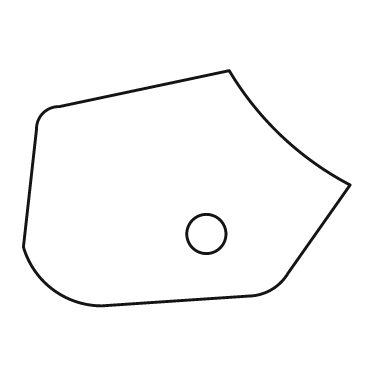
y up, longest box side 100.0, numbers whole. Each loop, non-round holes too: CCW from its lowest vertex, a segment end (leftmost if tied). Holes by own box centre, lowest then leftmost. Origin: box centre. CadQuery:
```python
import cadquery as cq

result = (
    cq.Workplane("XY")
    .moveTo(-26.0, -36.0)
    .lineTo(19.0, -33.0)
    .threePointArc((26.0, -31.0), (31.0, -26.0))
    .lineTo(50.0, 1.0)
    .threePointArc((29.0, 16.0), (13.0, 36.0))
    .lineTo(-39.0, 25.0)
    .threePointArc((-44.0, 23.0), (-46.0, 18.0))
    .lineTo(-50.0, -18.0)
    .threePointArc((-41.0, -31.0), (-26.0, -36.0))
    .close()
    .moveTo(6.0, -14.0)
    .circle(6.0)
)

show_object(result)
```